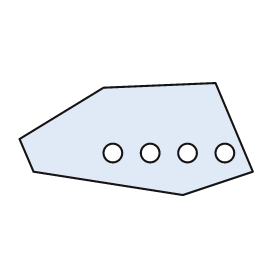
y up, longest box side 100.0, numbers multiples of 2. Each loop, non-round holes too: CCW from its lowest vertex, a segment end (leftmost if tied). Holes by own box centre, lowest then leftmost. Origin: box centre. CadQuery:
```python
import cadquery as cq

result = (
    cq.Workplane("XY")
    .moveTo(20.0, -24.0)
    .lineTo(50.0, -14.0)
    .lineTo(34.0, 24.0)
    .lineTo(-14.0, 22.0)
    .lineTo(-50.0, 0.0)
    .lineTo(-44.0, -14.0)
    .close()
    .moveTo(-10.0, -6.0)
    .circle(4.0)
    .moveTo(6.0, -6.0)
    .circle(4.0)
    .moveTo(22.0, -6.0)
    .circle(4.0)
    .moveTo(38.0, -6.0)
    .circle(4.0)
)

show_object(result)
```